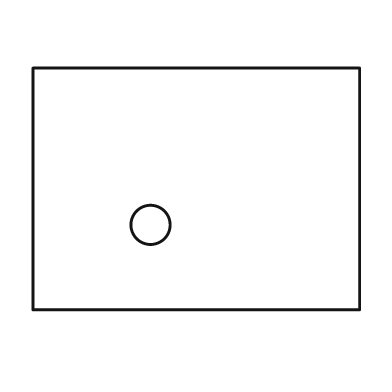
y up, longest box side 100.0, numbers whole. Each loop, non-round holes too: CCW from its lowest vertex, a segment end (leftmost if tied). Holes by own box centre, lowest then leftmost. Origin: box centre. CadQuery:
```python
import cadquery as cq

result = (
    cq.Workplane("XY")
    .moveTo(-50.0, -37.0)
    .lineTo(50.0, -37.0)
    .lineTo(50.0, 37.0)
    .lineTo(-50.0, 37.0)
    .close()
    .moveTo(-14.0, -11.0)
    .circle(6.0)
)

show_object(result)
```